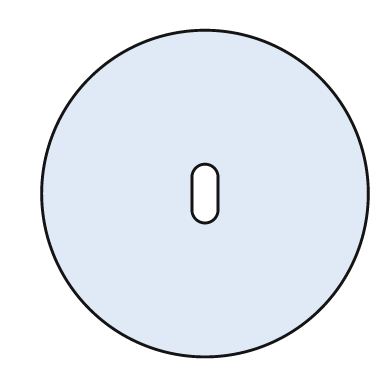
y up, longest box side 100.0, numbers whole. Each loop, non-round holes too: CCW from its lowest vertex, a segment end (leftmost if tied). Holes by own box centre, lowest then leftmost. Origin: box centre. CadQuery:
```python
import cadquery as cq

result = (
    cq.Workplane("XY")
    .moveTo(0.0, 0.0)
    .circle(50.0)
    .moveTo(-4.0, -5.0)
    .threePointArc((0.0, -9.0), (4.0, -5.0))
    .lineTo(4.0, 5.0)
    .threePointArc((0.0, 9.0), (-4.0, 5.0))
    .close()
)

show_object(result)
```